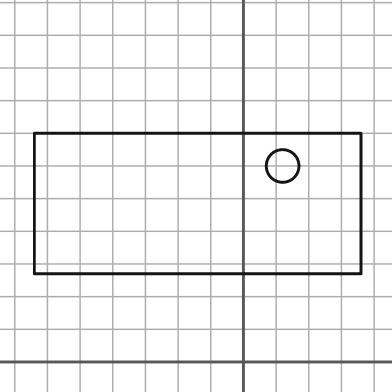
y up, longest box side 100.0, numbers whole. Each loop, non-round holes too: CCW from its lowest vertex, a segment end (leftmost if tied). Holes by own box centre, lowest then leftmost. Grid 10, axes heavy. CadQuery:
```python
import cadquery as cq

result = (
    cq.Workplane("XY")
    .moveTo(-64.0, 27.0)
    .lineTo(36.0, 27.0)
    .lineTo(36.0, 70.0)
    .lineTo(-64.0, 70.0)
    .close()
    .moveTo(12.0, 60.0)
    .circle(5.0)
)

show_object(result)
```